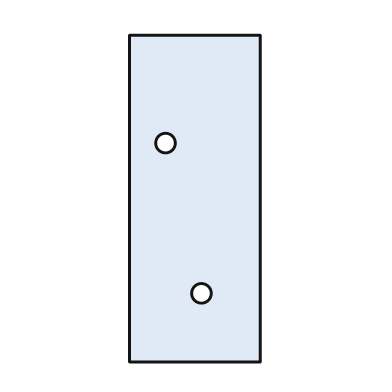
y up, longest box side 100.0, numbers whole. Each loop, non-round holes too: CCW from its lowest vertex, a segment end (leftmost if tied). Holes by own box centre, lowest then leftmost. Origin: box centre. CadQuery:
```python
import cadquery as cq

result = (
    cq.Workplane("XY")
    .moveTo(-20.0, -50.0)
    .lineTo(20.0, -50.0)
    .lineTo(20.0, 50.0)
    .lineTo(-20.0, 50.0)
    .close()
    .moveTo(2.0, -29.0)
    .circle(3.0)
    .moveTo(-9.0, 17.0)
    .circle(3.0)
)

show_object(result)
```